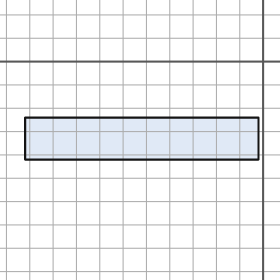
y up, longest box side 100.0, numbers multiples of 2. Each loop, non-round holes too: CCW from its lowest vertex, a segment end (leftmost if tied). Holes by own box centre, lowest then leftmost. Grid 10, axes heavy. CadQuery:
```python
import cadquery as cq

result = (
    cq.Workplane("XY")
    .moveTo(-102.0, -42.0)
    .lineTo(-2.0, -42.0)
    .lineTo(-2.0, -24.0)
    .lineTo(-102.0, -24.0)
    .close()
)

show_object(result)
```